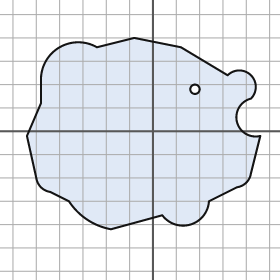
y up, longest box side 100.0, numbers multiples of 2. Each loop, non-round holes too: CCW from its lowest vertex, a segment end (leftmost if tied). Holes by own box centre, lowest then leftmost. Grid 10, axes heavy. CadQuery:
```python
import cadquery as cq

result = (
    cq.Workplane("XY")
    .moveTo(-18.0, -42.0)
    .lineTo(4.0, -36.0)
    .threePointArc((16.0, -40.0), (24.0, -30.0))
    .lineTo(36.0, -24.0)
    .threePointArc((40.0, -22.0), (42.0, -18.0))
    .lineTo(46.0, -2.0)
    .threePointArc((36.0, 4.0), (42.0, 14.0))
    .threePointArc((42.0, 24.0), (32.0, 24.0))
    .lineTo(12.0, 36.0)
    .lineTo(-8.0, 40.0)
    .lineTo(-24.0, 36.0)
    .threePointArc((-40.0, 36.0), (-48.0, 22.0))
    .lineTo(-48.0, 12.0)
    .lineTo(-54.0, -2.0)
    .lineTo(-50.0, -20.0)
    .threePointArc((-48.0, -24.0), (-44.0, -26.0))
    .lineTo(-36.0, -30.0)
    .threePointArc((-28.0, -38.0), (-18.0, -42.0))
    .close()
    .moveTo(18.0, 18.0)
    .circle(2.0)
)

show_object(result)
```